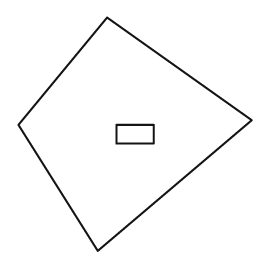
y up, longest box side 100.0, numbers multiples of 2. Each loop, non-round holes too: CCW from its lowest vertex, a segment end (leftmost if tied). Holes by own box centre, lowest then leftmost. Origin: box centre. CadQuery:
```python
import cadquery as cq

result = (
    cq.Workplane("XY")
    .moveTo(-16.0, -50.0)
    .lineTo(50.0, 6.0)
    .lineTo(-12.0, 50.0)
    .lineTo(-50.0, 4.0)
    .close()
    .moveTo(-8.0, -4.0)
    .lineTo(8.0, -4.0)
    .lineTo(8.0, 4.0)
    .lineTo(-8.0, 4.0)
    .close()
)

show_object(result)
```